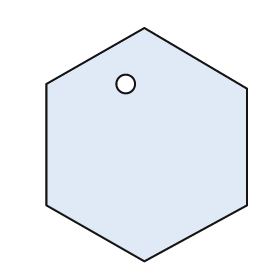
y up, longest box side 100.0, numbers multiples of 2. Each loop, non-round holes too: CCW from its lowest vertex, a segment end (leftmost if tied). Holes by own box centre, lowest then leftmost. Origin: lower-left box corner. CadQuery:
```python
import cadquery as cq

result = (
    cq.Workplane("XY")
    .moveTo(42.0, 0.0)
    .lineTo(86.0, 24.0)
    .lineTo(86.0, 74.0)
    .lineTo(42.0, 100.0)
    .lineTo(0.0, 76.0)
    .lineTo(0.0, 24.0)
    .close()
    .moveTo(34.0, 76.0)
    .circle(4.0)
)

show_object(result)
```